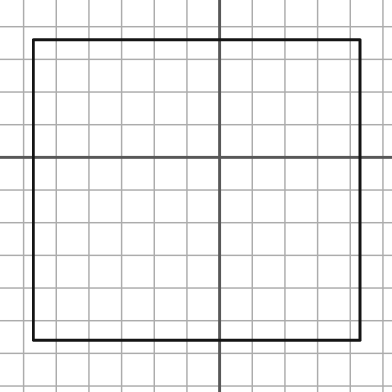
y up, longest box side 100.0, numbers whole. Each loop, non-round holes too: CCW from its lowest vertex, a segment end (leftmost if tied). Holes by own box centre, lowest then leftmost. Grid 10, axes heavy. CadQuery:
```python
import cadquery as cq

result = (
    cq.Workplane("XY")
    .moveTo(-57.0, -56.0)
    .lineTo(43.0, -56.0)
    .lineTo(43.0, 36.0)
    .lineTo(-57.0, 36.0)
    .close()
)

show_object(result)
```